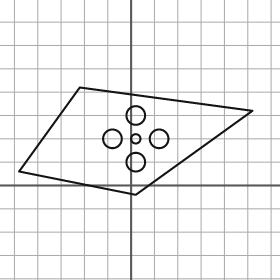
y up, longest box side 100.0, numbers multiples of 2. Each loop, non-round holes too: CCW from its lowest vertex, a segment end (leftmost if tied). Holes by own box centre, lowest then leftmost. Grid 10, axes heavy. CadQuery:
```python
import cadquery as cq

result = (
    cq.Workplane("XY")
    .moveTo(2.0, -4.0)
    .lineTo(52.0, 32.0)
    .lineTo(-22.0, 42.0)
    .lineTo(-48.0, 6.0)
    .close()
    .moveTo(2.0, 10.0)
    .circle(4.0)
    .moveTo(-8.0, 20.0)
    .circle(4.0)
    .moveTo(2.0, 20.0)
    .circle(2.0)
    .moveTo(12.0, 20.0)
    .circle(4.0)
    .moveTo(2.0, 30.0)
    .circle(4.0)
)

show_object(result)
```